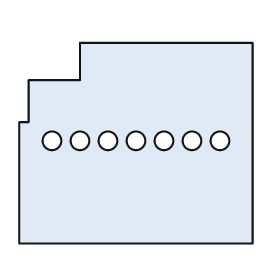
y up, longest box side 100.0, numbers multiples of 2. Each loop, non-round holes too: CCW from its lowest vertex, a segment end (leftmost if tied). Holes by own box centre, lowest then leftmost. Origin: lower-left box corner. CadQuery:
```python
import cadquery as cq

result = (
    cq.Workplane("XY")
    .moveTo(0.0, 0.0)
    .lineTo(100.0, 0.0)
    .lineTo(100.0, 86.0)
    .lineTo(26.0, 86.0)
    .lineTo(26.0, 70.0)
    .lineTo(4.0, 70.0)
    .lineTo(4.0, 52.0)
    .lineTo(0.0, 52.0)
    .close()
    .moveTo(14.0, 44.0)
    .circle(4.0)
    .moveTo(26.0, 44.0)
    .circle(4.0)
    .moveTo(38.0, 44.0)
    .circle(4.0)
    .moveTo(50.0, 44.0)
    .circle(4.0)
    .moveTo(62.0, 44.0)
    .circle(4.0)
    .moveTo(74.0, 44.0)
    .circle(4.0)
    .moveTo(86.0, 44.0)
    .circle(4.0)
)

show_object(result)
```